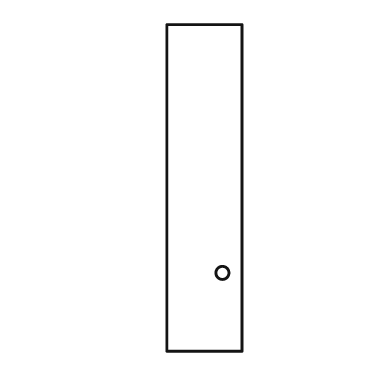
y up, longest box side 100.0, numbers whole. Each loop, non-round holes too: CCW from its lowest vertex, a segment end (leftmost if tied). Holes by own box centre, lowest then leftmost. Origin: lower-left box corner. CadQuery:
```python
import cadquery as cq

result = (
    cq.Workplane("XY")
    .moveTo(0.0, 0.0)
    .lineTo(23.0, 0.0)
    .lineTo(23.0, 100.0)
    .lineTo(0.0, 100.0)
    .close()
    .moveTo(17.0, 24.0)
    .circle(2.0)
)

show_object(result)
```